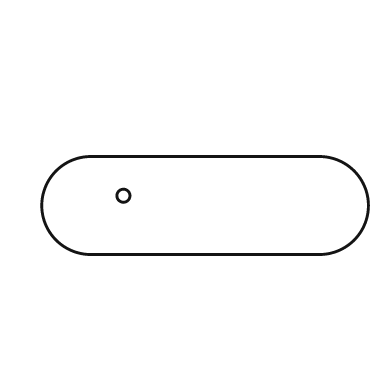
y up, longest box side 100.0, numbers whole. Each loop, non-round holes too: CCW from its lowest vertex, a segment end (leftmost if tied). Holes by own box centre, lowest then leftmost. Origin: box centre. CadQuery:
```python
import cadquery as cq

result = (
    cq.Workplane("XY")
    .moveTo(-35.0, -15.0)
    .lineTo(35.0, -15.0)
    .threePointArc((50.0, 0.0), (35.0, 15.0))
    .lineTo(-35.0, 15.0)
    .threePointArc((-50.0, 0.0), (-35.0, -15.0))
    .close()
    .moveTo(-25.0, 3.0)
    .circle(2.0)
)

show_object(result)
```